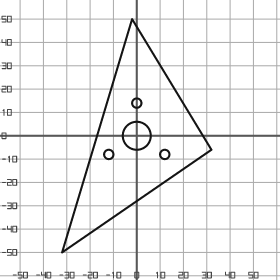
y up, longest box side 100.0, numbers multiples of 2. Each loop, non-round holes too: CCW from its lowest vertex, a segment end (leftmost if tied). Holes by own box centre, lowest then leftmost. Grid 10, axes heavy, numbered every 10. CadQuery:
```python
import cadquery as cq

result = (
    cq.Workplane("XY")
    .moveTo(-32.0, -50.0)
    .lineTo(32.0, -6.0)
    .lineTo(-2.0, 50.0)
    .close()
    .moveTo(-12.0, -8.0)
    .circle(2.0)
    .moveTo(12.0, -8.0)
    .circle(2.0)
    .moveTo(0.0, 0.0)
    .circle(6.0)
    .moveTo(0.0, 14.0)
    .circle(2.0)
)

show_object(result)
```